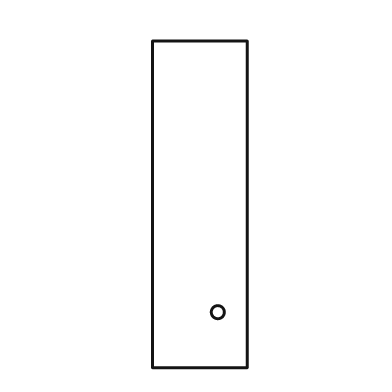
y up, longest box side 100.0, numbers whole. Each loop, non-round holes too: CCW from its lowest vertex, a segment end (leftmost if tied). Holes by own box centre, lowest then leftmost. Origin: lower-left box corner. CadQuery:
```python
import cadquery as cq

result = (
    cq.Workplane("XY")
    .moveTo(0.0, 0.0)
    .lineTo(29.0, 0.0)
    .lineTo(29.0, 100.0)
    .lineTo(0.0, 100.0)
    .close()
    .moveTo(20.0, 17.0)
    .circle(2.0)
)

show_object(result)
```